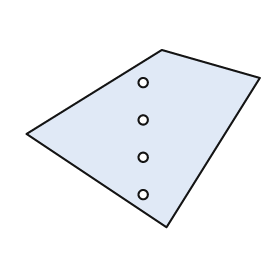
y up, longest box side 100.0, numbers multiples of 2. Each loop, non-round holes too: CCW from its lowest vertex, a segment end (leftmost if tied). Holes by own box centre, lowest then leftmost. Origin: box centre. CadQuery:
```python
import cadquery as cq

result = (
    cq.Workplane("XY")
    .moveTo(10.0, -38.0)
    .lineTo(50.0, 26.0)
    .lineTo(8.0, 38.0)
    .lineTo(-50.0, 2.0)
    .close()
    .moveTo(0.0, -24.0)
    .circle(2.0)
    .moveTo(0.0, -8.0)
    .circle(2.0)
    .moveTo(0.0, 8.0)
    .circle(2.0)
    .moveTo(0.0, 24.0)
    .circle(2.0)
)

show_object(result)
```